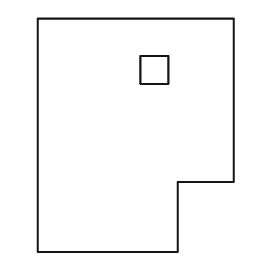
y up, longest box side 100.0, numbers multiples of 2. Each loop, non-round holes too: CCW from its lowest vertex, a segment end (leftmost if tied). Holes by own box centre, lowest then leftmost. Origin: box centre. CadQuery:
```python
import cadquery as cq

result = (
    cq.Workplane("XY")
    .moveTo(-42.0, -50.0)
    .lineTo(18.0, -50.0)
    .lineTo(18.0, -20.0)
    .lineTo(42.0, -20.0)
    .lineTo(42.0, 50.0)
    .lineTo(-42.0, 50.0)
    .close()
    .moveTo(2.0, 22.0)
    .lineTo(14.0, 22.0)
    .lineTo(14.0, 34.0)
    .lineTo(2.0, 34.0)
    .close()
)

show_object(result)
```